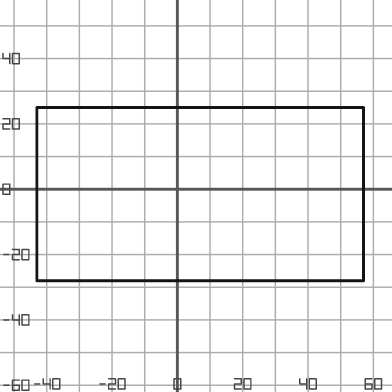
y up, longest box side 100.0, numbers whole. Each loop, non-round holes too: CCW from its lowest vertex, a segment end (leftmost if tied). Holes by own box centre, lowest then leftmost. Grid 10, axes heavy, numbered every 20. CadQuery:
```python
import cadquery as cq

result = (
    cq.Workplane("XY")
    .moveTo(-43.0, -28.0)
    .lineTo(57.0, -28.0)
    .lineTo(57.0, 25.0)
    .lineTo(-43.0, 25.0)
    .close()
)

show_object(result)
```